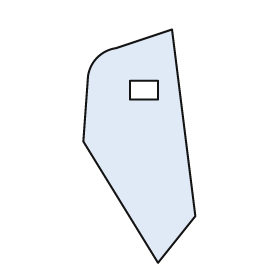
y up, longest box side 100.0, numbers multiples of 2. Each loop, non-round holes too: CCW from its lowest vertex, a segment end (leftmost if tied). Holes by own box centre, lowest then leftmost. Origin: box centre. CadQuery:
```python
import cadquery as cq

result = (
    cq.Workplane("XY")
    .moveTo(8.0, -50.0)
    .lineTo(24.0, -30.0)
    .lineTo(14.0, 50.0)
    .lineTo(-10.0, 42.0)
    .threePointArc((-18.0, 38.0), (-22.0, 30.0))
    .lineTo(-24.0, 2.0)
    .close()
    .moveTo(-4.0, 20.0)
    .lineTo(8.0, 20.0)
    .lineTo(8.0, 28.0)
    .lineTo(-4.0, 28.0)
    .close()
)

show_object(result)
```